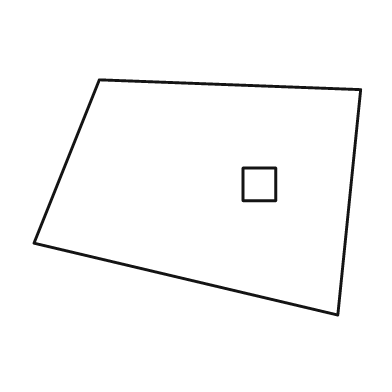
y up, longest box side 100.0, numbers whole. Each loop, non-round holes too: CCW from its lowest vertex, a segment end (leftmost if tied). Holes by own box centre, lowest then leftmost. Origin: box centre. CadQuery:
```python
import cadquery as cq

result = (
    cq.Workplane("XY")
    .moveTo(43.0, -36.0)
    .lineTo(50.0, 33.0)
    .lineTo(-30.0, 36.0)
    .lineTo(-50.0, -14.0)
    .close()
    .moveTo(14.0, -1.0)
    .lineTo(24.0, -1.0)
    .lineTo(24.0, 9.0)
    .lineTo(14.0, 9.0)
    .close()
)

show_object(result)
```